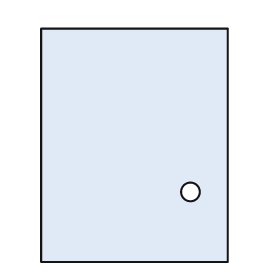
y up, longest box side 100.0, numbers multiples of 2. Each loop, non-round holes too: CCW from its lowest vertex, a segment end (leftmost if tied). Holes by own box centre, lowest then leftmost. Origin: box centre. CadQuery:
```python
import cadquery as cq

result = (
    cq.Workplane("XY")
    .moveTo(-40.0, -50.0)
    .lineTo(40.0, -50.0)
    .lineTo(40.0, 50.0)
    .lineTo(-40.0, 50.0)
    .close()
    .moveTo(24.0, -20.0)
    .circle(4.0)
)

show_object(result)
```